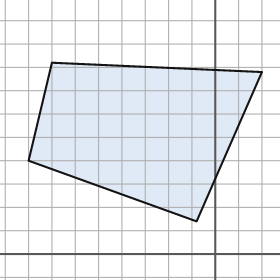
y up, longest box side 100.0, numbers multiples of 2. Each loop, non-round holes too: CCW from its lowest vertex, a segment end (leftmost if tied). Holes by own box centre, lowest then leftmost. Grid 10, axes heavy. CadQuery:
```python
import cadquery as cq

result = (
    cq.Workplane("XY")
    .moveTo(-8.0, 14.0)
    .lineTo(20.0, 78.0)
    .lineTo(-70.0, 82.0)
    .lineTo(-80.0, 40.0)
    .close()
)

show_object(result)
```